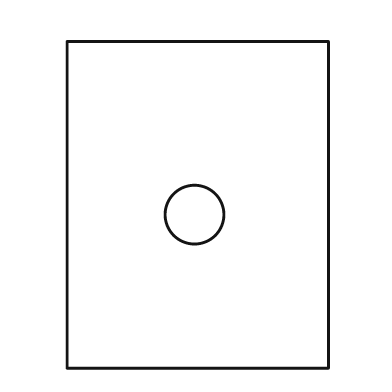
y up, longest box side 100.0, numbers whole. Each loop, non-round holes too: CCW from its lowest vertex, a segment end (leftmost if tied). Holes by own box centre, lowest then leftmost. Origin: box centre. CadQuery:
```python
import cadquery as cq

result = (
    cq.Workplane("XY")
    .moveTo(-40.0, -50.0)
    .lineTo(40.0, -50.0)
    .lineTo(40.0, 50.0)
    .lineTo(-40.0, 50.0)
    .close()
    .moveTo(-1.0, -3.0)
    .circle(9.0)
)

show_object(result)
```